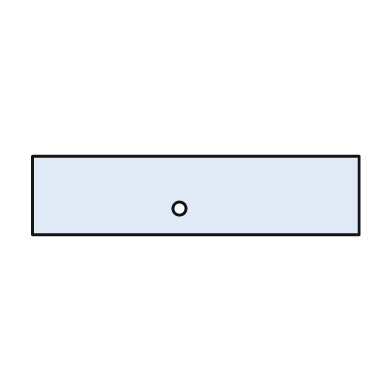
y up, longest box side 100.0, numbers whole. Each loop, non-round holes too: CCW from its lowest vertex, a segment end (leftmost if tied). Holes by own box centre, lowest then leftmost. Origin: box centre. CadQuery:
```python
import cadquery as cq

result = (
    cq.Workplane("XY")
    .moveTo(-50.0, -12.0)
    .lineTo(50.0, -12.0)
    .lineTo(50.0, 12.0)
    .lineTo(-50.0, 12.0)
    .close()
    .moveTo(-5.0, -4.0)
    .circle(2.0)
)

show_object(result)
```